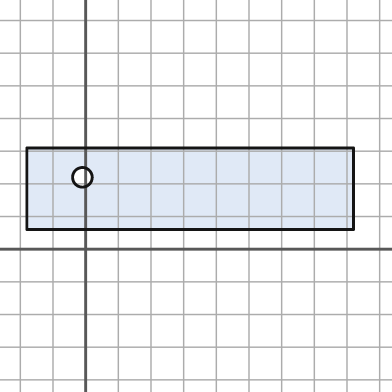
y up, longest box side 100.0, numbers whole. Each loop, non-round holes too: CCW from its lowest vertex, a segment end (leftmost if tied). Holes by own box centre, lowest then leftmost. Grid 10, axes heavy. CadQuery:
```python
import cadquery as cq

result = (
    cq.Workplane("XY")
    .moveTo(-18.0, 6.0)
    .lineTo(82.0, 6.0)
    .lineTo(82.0, 31.0)
    .lineTo(-18.0, 31.0)
    .close()
    .moveTo(-1.0, 22.0)
    .circle(3.0)
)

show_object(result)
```